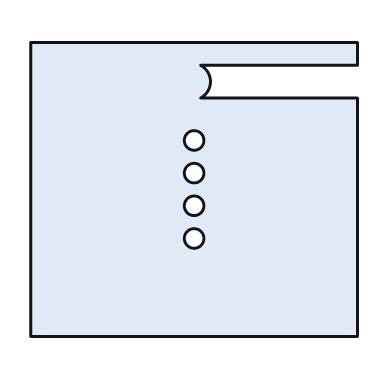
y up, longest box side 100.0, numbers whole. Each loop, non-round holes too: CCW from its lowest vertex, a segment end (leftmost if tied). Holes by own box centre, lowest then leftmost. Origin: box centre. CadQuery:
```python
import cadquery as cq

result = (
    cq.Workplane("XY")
    .moveTo(-50.0, -45.0)
    .lineTo(50.0, -45.0)
    .lineTo(50.0, 28.0)
    .lineTo(2.0, 28.0)
    .threePointArc((5.0, 33.0), (2.0, 38.0))
    .lineTo(50.0, 38.0)
    .lineTo(50.0, 45.0)
    .lineTo(-50.0, 45.0)
    .close()
    .moveTo(0.0, -15.0)
    .circle(3.0)
    .moveTo(0.0, -5.0)
    .circle(3.0)
    .moveTo(0.0, 5.0)
    .circle(3.0)
    .moveTo(0.0, 15.0)
    .circle(3.0)
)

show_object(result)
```